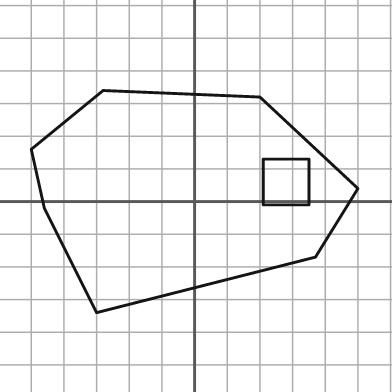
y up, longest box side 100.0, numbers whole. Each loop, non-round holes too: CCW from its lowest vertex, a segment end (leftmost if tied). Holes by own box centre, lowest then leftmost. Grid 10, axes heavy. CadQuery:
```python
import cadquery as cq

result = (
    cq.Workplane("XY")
    .moveTo(-30.0, -34.0)
    .lineTo(37.0, -17.0)
    .lineTo(50.0, 4.0)
    .lineTo(20.0, 32.0)
    .lineTo(-28.0, 34.0)
    .lineTo(-50.0, 16.0)
    .lineTo(-46.0, -2.0)
    .close()
    .moveTo(21.0, -1.0)
    .lineTo(35.0, -1.0)
    .lineTo(35.0, 13.0)
    .lineTo(21.0, 13.0)
    .close()
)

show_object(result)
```